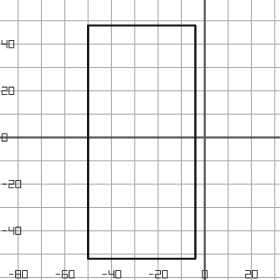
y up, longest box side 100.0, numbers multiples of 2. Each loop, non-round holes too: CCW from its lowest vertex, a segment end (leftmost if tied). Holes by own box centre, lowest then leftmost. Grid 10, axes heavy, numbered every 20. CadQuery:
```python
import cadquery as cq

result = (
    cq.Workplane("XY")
    .moveTo(-50.0, -52.0)
    .lineTo(-4.0, -52.0)
    .lineTo(-4.0, 48.0)
    .lineTo(-50.0, 48.0)
    .close()
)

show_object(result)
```